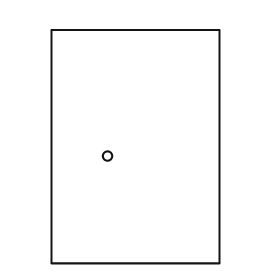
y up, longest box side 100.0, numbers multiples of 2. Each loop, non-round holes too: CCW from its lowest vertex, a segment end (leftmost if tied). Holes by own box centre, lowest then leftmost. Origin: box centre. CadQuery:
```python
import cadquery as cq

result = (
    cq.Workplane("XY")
    .moveTo(-36.0, -50.0)
    .lineTo(36.0, -50.0)
    .lineTo(36.0, 50.0)
    .lineTo(-36.0, 50.0)
    .close()
    .moveTo(-12.0, -4.0)
    .circle(2.0)
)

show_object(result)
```